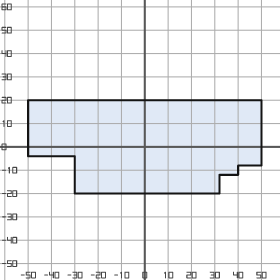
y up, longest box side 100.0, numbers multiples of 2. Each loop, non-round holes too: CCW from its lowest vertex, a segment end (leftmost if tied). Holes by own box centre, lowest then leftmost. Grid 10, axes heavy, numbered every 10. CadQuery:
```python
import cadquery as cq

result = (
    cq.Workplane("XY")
    .moveTo(-30.0, -20.0)
    .lineTo(32.0, -20.0)
    .lineTo(32.0, -12.0)
    .lineTo(40.0, -12.0)
    .lineTo(40.0, -8.0)
    .lineTo(50.0, -8.0)
    .lineTo(50.0, 20.0)
    .lineTo(-50.0, 20.0)
    .lineTo(-50.0, -4.0)
    .lineTo(-30.0, -4.0)
    .close()
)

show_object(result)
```